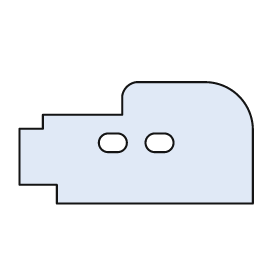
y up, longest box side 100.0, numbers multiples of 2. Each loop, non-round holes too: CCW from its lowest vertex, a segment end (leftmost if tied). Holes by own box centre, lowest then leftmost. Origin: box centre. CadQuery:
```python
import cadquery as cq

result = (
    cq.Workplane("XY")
    .moveTo(-34.0, -26.0)
    .lineTo(50.0, -26.0)
    .lineTo(50.0, 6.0)
    .threePointArc((44.0, 20.0), (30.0, 26.0))
    .lineTo(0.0, 26.0)
    .threePointArc((-4.0, 24.0), (-6.0, 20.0))
    .lineTo(-6.0, 12.0)
    .lineTo(-40.0, 12.0)
    .lineTo(-40.0, 6.0)
    .lineTo(-50.0, 6.0)
    .lineTo(-50.0, -18.0)
    .lineTo(-34.0, -18.0)
    .close()
    .moveTo(-12.0, -4.0)
    .lineTo(-8.0, -4.0)
    .threePointArc((-4.0, 0.0), (-8.0, 4.0))
    .lineTo(-12.0, 4.0)
    .threePointArc((-16.0, 0.0), (-12.0, -4.0))
    .close()
    .moveTo(8.0, -4.0)
    .lineTo(12.0, -4.0)
    .threePointArc((16.0, 0.0), (12.0, 4.0))
    .lineTo(8.0, 4.0)
    .threePointArc((4.0, 0.0), (8.0, -4.0))
    .close()
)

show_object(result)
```